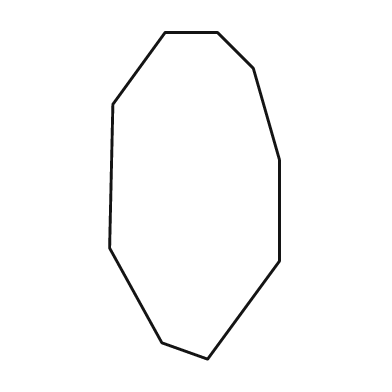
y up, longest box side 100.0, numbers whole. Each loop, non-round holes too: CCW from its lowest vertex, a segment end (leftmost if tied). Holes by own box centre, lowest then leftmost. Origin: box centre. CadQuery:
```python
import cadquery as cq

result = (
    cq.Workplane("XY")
    .moveTo(4.0, -50.0)
    .lineTo(26.0, -20.0)
    .lineTo(26.0, 11.0)
    .lineTo(18.0, 39.0)
    .lineTo(7.0, 50.0)
    .lineTo(-9.0, 50.0)
    .lineTo(-25.0, 28.0)
    .lineTo(-26.0, -16.0)
    .lineTo(-10.0, -45.0)
    .close()
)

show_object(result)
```